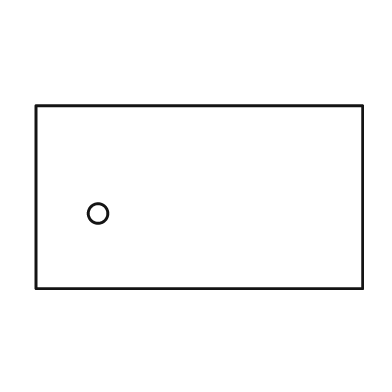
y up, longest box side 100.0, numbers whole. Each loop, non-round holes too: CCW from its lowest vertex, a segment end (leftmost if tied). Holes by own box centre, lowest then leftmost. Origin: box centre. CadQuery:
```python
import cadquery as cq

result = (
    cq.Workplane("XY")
    .moveTo(-50.0, -28.0)
    .lineTo(50.0, -28.0)
    .lineTo(50.0, 28.0)
    .lineTo(-50.0, 28.0)
    .close()
    .moveTo(-31.0, -5.0)
    .circle(3.0)
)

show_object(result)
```